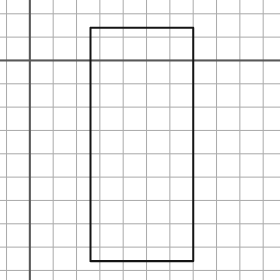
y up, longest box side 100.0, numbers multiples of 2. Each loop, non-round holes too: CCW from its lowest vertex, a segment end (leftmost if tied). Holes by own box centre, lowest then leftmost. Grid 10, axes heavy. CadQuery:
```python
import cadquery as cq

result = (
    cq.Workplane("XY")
    .moveTo(26.0, -86.0)
    .lineTo(70.0, -86.0)
    .lineTo(70.0, 14.0)
    .lineTo(26.0, 14.0)
    .close()
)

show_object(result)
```